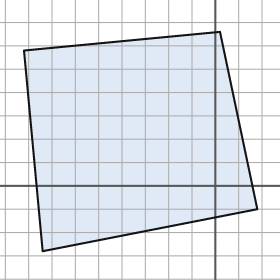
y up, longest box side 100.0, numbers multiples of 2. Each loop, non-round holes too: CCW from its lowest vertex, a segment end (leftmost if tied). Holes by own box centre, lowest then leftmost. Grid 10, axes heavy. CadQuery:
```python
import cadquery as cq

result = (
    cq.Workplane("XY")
    .moveTo(-74.0, -28.0)
    .lineTo(18.0, -10.0)
    .lineTo(2.0, 66.0)
    .lineTo(-82.0, 58.0)
    .close()
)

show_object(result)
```